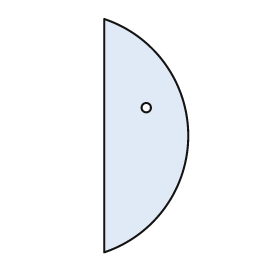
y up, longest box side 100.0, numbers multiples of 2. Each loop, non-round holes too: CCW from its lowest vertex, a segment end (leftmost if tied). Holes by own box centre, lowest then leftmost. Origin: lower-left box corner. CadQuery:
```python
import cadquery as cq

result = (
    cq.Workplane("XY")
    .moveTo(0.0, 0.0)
    .threePointArc((36.0, 50.0), (0.0, 100.0))
    .close()
    .moveTo(18.0, 62.0)
    .circle(2.0)
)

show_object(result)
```